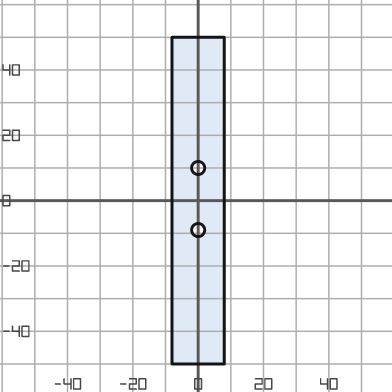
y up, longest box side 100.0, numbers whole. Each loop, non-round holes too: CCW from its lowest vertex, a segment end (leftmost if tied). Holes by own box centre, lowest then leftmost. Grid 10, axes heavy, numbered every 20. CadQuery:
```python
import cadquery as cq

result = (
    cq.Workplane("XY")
    .moveTo(-8.0, -50.0)
    .lineTo(8.0, -50.0)
    .lineTo(8.0, 50.0)
    .lineTo(-8.0, 50.0)
    .close()
    .moveTo(0.0, -9.0)
    .circle(2.0)
    .moveTo(0.0, 10.0)
    .circle(2.0)
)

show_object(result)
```